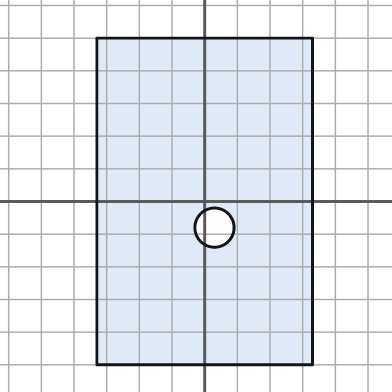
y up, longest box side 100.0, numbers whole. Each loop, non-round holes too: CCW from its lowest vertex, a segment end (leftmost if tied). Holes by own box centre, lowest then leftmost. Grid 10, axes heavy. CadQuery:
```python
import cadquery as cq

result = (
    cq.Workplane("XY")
    .moveTo(-33.0, -50.0)
    .lineTo(33.0, -50.0)
    .lineTo(33.0, 50.0)
    .lineTo(-33.0, 50.0)
    .close()
    .moveTo(3.0, -8.0)
    .circle(6.0)
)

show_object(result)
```